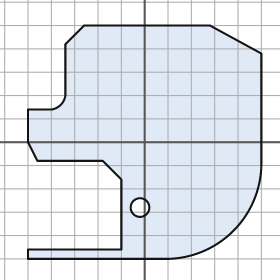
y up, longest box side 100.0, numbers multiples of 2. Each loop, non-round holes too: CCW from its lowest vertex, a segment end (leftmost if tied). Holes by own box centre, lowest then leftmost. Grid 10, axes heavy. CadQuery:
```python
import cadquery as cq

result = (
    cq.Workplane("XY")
    .moveTo(-50.0, -50.0)
    .lineTo(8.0, -50.0)
    .threePointArc((38.0, -38.0), (50.0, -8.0))
    .lineTo(50.0, 38.0)
    .lineTo(28.0, 50.0)
    .lineTo(-26.0, 50.0)
    .lineTo(-34.0, 42.0)
    .lineTo(-34.0, 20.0)
    .threePointArc((-36.0, 16.0), (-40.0, 14.0))
    .lineTo(-50.0, 14.0)
    .lineTo(-50.0, 0.0)
    .lineTo(-46.0, -8.0)
    .lineTo(-18.0, -8.0)
    .lineTo(-10.0, -16.0)
    .lineTo(-10.0, -46.0)
    .lineTo(-50.0, -46.0)
    .close()
    .moveTo(-2.0, -28.0)
    .circle(4.0)
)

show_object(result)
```